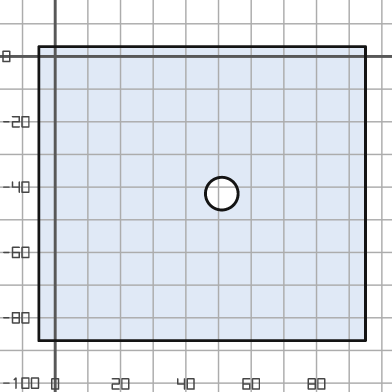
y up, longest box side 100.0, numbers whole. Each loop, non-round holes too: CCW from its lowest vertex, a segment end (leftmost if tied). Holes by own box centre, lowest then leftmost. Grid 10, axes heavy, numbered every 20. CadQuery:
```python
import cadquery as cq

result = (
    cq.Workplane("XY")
    .moveTo(-5.0, -87.0)
    .lineTo(95.0, -87.0)
    .lineTo(95.0, 3.0)
    .lineTo(-5.0, 3.0)
    .close()
    .moveTo(51.0, -42.0)
    .circle(5.0)
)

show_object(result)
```